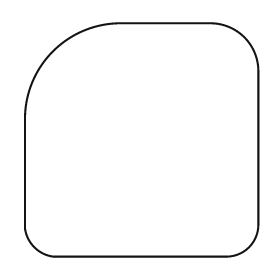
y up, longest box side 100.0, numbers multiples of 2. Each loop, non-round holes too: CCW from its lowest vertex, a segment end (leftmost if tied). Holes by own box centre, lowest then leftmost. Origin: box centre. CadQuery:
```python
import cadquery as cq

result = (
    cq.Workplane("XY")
    .moveTo(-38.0, -50.0)
    .lineTo(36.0, -50.0)
    .threePointArc((46.0, -46.0), (50.0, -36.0))
    .lineTo(50.0, 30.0)
    .threePointArc((44.0, 44.0), (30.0, 50.0))
    .lineTo(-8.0, 50.0)
    .threePointArc((-38.0, 38.0), (-50.0, 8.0))
    .lineTo(-50.0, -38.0)
    .threePointArc((-46.0, -46.0), (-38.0, -50.0))
    .close()
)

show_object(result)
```